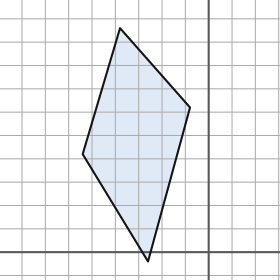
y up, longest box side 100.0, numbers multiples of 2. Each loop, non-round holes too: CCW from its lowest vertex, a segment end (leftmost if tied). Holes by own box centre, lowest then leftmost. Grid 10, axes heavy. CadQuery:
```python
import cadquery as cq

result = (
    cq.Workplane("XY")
    .moveTo(-26.0, -4.0)
    .lineTo(-8.0, 62.0)
    .lineTo(-38.0, 96.0)
    .lineTo(-54.0, 42.0)
    .close()
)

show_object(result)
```